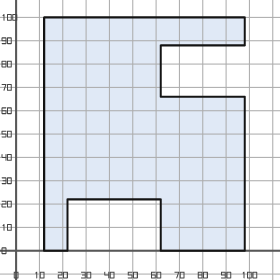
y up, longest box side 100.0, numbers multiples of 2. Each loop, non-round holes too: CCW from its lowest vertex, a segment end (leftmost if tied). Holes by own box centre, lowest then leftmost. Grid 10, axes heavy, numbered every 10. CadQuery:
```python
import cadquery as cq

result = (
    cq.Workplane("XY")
    .moveTo(12.0, 0.0)
    .lineTo(22.0, 0.0)
    .lineTo(22.0, 22.0)
    .lineTo(62.0, 22.0)
    .lineTo(62.0, 0.0)
    .lineTo(98.0, 0.0)
    .lineTo(98.0, 66.0)
    .lineTo(62.0, 66.0)
    .lineTo(62.0, 88.0)
    .lineTo(98.0, 88.0)
    .lineTo(98.0, 100.0)
    .lineTo(12.0, 100.0)
    .close()
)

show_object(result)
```